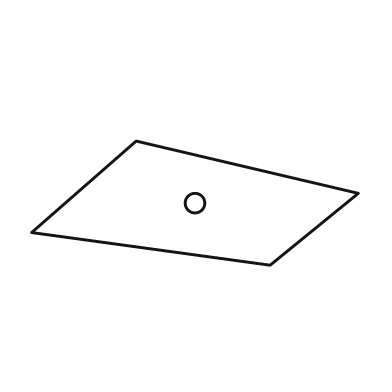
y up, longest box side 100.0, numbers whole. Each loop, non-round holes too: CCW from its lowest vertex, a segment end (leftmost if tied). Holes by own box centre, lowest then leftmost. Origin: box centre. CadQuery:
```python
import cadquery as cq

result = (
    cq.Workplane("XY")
    .moveTo(23.0, -19.0)
    .lineTo(50.0, 3.0)
    .lineTo(-18.0, 19.0)
    .lineTo(-50.0, -9.0)
    .close()
    .moveTo(0.0, 0.0)
    .circle(3.0)
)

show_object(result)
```